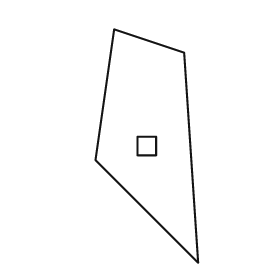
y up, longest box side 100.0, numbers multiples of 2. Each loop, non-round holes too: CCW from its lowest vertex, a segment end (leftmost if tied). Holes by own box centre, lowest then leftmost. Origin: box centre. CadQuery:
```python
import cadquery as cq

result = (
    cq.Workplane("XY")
    .moveTo(22.0, -50.0)
    .lineTo(16.0, 40.0)
    .lineTo(-14.0, 50.0)
    .lineTo(-22.0, -6.0)
    .close()
    .moveTo(-4.0, -4.0)
    .lineTo(4.0, -4.0)
    .lineTo(4.0, 4.0)
    .lineTo(-4.0, 4.0)
    .close()
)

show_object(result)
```